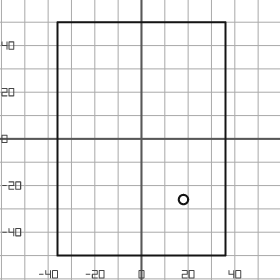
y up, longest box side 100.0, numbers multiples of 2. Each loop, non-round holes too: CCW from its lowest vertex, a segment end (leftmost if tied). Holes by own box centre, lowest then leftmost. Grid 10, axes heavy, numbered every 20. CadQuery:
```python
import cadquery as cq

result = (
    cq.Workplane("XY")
    .moveTo(-36.0, -50.0)
    .lineTo(36.0, -50.0)
    .lineTo(36.0, 50.0)
    .lineTo(-36.0, 50.0)
    .close()
    .moveTo(18.0, -26.0)
    .circle(2.0)
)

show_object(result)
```